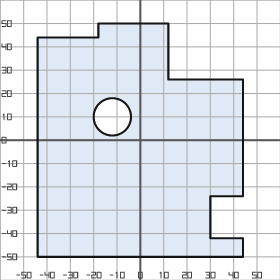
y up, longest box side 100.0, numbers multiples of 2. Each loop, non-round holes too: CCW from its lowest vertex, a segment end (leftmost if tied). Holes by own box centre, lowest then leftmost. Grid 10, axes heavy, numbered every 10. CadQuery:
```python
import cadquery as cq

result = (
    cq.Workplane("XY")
    .moveTo(-44.0, -50.0)
    .lineTo(44.0, -50.0)
    .lineTo(44.0, -42.0)
    .lineTo(30.0, -42.0)
    .lineTo(30.0, -24.0)
    .lineTo(44.0, -24.0)
    .lineTo(44.0, 26.0)
    .lineTo(12.0, 26.0)
    .lineTo(12.0, 50.0)
    .lineTo(-18.0, 50.0)
    .lineTo(-18.0, 44.0)
    .lineTo(-44.0, 44.0)
    .close()
    .moveTo(-12.0, 10.0)
    .circle(8.0)
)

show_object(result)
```